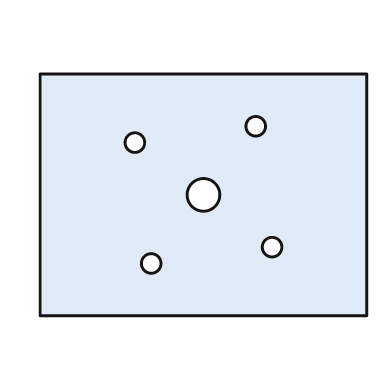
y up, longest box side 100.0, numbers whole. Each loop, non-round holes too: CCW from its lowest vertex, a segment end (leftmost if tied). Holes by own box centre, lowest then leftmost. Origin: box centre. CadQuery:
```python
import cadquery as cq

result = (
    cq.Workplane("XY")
    .moveTo(-50.0, -37.0)
    .lineTo(50.0, -37.0)
    .lineTo(50.0, 37.0)
    .lineTo(-50.0, 37.0)
    .close()
    .moveTo(-16.0, -21.0)
    .circle(3.0)
    .moveTo(21.0, -16.0)
    .circle(3.0)
    .moveTo(0.0, 0.0)
    .circle(5.0)
    .moveTo(-21.0, 16.0)
    .circle(3.0)
    .moveTo(16.0, 21.0)
    .circle(3.0)
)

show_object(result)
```